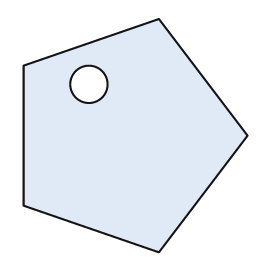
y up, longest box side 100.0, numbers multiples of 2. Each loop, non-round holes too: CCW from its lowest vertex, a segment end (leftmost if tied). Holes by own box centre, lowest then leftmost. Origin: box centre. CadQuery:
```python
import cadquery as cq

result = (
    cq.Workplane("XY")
    .moveTo(10.0, -50.0)
    .lineTo(48.0, 0.0)
    .lineTo(10.0, 50.0)
    .lineTo(-48.0, 30.0)
    .lineTo(-48.0, -30.0)
    .close()
    .moveTo(-20.0, 22.0)
    .circle(8.0)
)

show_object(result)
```